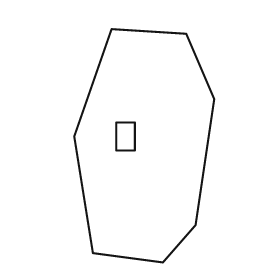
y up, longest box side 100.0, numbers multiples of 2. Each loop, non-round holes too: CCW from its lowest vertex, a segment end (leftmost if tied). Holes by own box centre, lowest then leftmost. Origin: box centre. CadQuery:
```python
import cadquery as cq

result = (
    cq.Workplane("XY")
    .moveTo(8.0, -50.0)
    .lineTo(22.0, -34.0)
    .lineTo(30.0, 20.0)
    .lineTo(18.0, 48.0)
    .lineTo(-14.0, 50.0)
    .lineTo(-30.0, 4.0)
    .lineTo(-22.0, -46.0)
    .close()
    .moveTo(-12.0, -2.0)
    .lineTo(-4.0, -2.0)
    .lineTo(-4.0, 10.0)
    .lineTo(-12.0, 10.0)
    .close()
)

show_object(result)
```